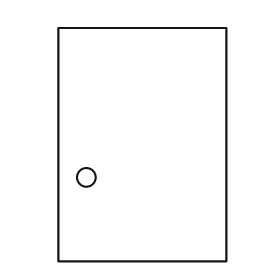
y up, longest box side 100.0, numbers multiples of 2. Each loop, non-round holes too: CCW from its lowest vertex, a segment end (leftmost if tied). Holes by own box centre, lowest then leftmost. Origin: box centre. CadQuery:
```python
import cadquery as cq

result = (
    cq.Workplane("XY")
    .moveTo(-36.0, -50.0)
    .lineTo(36.0, -50.0)
    .lineTo(36.0, 50.0)
    .lineTo(-36.0, 50.0)
    .close()
    .moveTo(-24.0, -14.0)
    .circle(4.0)
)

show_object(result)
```